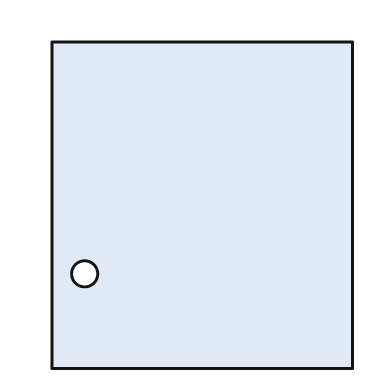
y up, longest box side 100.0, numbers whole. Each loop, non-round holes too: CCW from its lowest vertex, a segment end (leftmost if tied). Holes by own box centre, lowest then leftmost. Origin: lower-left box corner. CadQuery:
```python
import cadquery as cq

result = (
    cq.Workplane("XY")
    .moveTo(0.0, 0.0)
    .lineTo(92.0, 0.0)
    .lineTo(92.0, 100.0)
    .lineTo(0.0, 100.0)
    .close()
    .moveTo(10.0, 29.0)
    .circle(4.0)
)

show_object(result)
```